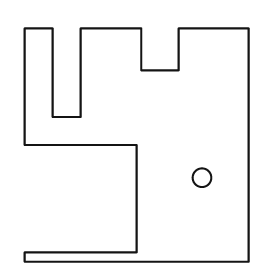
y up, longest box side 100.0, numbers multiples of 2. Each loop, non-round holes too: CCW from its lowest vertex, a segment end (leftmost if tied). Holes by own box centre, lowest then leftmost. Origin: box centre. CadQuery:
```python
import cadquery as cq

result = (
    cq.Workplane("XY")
    .moveTo(-48.0, -50.0)
    .lineTo(48.0, -50.0)
    .lineTo(48.0, 50.0)
    .lineTo(18.0, 50.0)
    .lineTo(18.0, 32.0)
    .lineTo(2.0, 32.0)
    .lineTo(2.0, 50.0)
    .lineTo(-24.0, 50.0)
    .lineTo(-24.0, 12.0)
    .lineTo(-36.0, 12.0)
    .lineTo(-36.0, 50.0)
    .lineTo(-48.0, 50.0)
    .lineTo(-48.0, 0.0)
    .lineTo(0.0, 0.0)
    .lineTo(0.0, -46.0)
    .lineTo(-48.0, -46.0)
    .close()
    .moveTo(28.0, -14.0)
    .circle(4.0)
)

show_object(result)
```